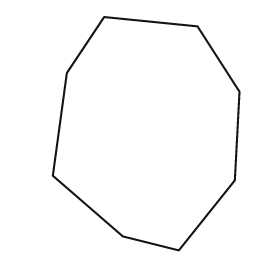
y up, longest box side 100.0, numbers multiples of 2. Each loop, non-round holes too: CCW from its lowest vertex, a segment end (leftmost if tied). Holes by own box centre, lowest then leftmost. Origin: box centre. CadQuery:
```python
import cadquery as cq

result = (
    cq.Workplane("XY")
    .moveTo(14.0, -50.0)
    .lineTo(38.0, -20.0)
    .lineTo(40.0, 18.0)
    .lineTo(22.0, 46.0)
    .lineTo(-18.0, 50.0)
    .lineTo(-34.0, 26.0)
    .lineTo(-40.0, -18.0)
    .lineTo(-10.0, -44.0)
    .close()
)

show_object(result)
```